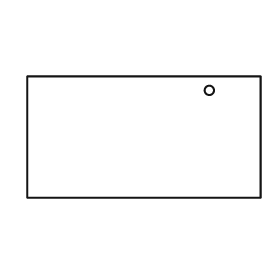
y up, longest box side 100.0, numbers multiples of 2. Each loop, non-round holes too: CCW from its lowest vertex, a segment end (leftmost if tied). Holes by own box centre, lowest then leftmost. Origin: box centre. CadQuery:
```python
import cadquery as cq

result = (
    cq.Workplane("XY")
    .moveTo(-50.0, -26.0)
    .lineTo(50.0, -26.0)
    .lineTo(50.0, 26.0)
    .lineTo(-50.0, 26.0)
    .close()
    .moveTo(28.0, 20.0)
    .circle(2.0)
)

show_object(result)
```